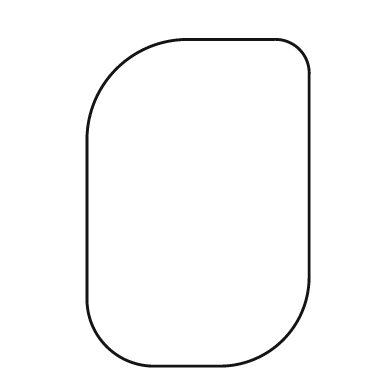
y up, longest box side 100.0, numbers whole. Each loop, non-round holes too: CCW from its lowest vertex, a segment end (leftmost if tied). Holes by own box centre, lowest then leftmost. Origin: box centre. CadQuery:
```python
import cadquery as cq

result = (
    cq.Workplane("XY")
    .moveTo(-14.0, -50.0)
    .lineTo(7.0, -50.0)
    .threePointArc((26.0, -42.0), (34.0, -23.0))
    .lineTo(34.0, 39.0)
    .threePointArc((31.0, 47.0), (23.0, 50.0))
    .lineTo(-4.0, 50.0)
    .threePointArc((-25.0, 41.0), (-34.0, 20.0))
    .lineTo(-34.0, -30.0)
    .threePointArc((-28.0, -44.0), (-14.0, -50.0))
    .close()
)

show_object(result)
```